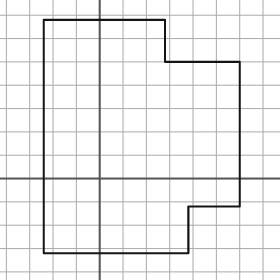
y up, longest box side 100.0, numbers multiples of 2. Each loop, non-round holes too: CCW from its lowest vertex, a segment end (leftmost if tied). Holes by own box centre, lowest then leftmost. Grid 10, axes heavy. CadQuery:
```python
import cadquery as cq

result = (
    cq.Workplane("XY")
    .moveTo(-24.0, -32.0)
    .lineTo(38.0, -32.0)
    .lineTo(38.0, -12.0)
    .lineTo(60.0, -12.0)
    .lineTo(60.0, 50.0)
    .lineTo(28.0, 50.0)
    .lineTo(28.0, 68.0)
    .lineTo(-24.0, 68.0)
    .close()
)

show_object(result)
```